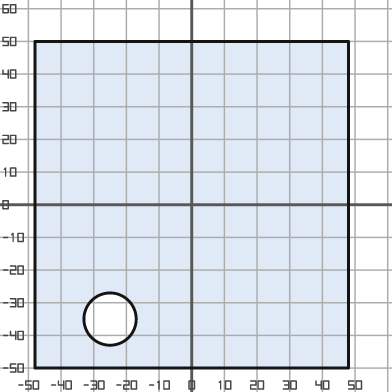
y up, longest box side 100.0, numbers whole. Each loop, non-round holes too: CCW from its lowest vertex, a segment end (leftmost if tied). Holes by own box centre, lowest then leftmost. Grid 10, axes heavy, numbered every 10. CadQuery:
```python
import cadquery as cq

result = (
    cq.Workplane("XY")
    .moveTo(-48.0, -50.0)
    .lineTo(48.0, -50.0)
    .lineTo(48.0, 50.0)
    .lineTo(-48.0, 50.0)
    .close()
    .moveTo(-25.0, -35.0)
    .circle(8.0)
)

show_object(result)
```